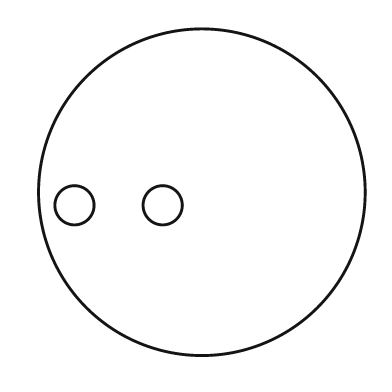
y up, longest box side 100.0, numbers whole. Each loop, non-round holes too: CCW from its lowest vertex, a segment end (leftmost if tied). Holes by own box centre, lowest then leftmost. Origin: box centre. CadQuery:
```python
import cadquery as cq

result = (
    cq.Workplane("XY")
    .moveTo(0.0, 0.0)
    .circle(50.0)
    .moveTo(-39.0, -4.0)
    .circle(6.0)
    .moveTo(-12.0, -4.0)
    .circle(6.0)
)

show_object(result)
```